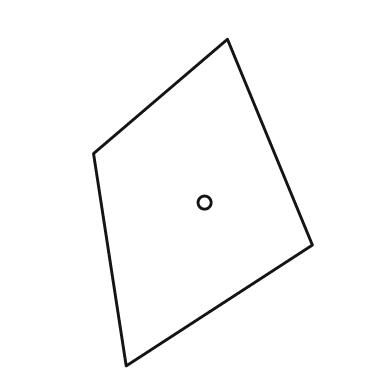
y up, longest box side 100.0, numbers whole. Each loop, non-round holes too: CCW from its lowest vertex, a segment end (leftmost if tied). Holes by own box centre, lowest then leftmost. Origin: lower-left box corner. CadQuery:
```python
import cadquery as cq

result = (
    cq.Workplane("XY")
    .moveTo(10.0, 0.0)
    .lineTo(67.0, 37.0)
    .lineTo(41.0, 100.0)
    .lineTo(0.0, 65.0)
    .close()
    .moveTo(34.0, 50.0)
    .circle(2.0)
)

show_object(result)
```